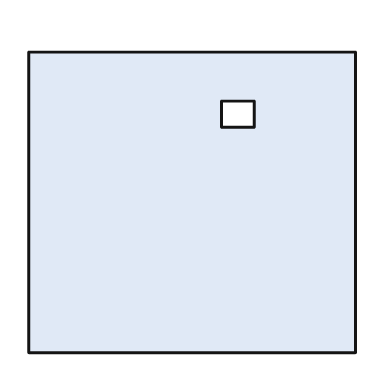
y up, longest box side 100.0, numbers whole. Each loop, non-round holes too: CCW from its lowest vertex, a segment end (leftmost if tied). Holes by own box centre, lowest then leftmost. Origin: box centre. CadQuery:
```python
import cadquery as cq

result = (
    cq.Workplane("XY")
    .moveTo(-50.0, -46.0)
    .lineTo(50.0, -46.0)
    .lineTo(50.0, 46.0)
    .lineTo(-50.0, 46.0)
    .close()
    .moveTo(9.0, 23.0)
    .lineTo(19.0, 23.0)
    .lineTo(19.0, 31.0)
    .lineTo(9.0, 31.0)
    .close()
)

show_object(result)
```